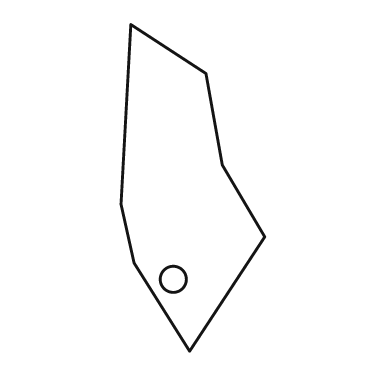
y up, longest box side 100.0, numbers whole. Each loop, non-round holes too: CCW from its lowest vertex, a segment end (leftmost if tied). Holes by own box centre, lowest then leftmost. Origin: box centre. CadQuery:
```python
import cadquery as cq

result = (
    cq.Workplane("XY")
    .moveTo(-1.0, -50.0)
    .lineTo(22.0, -15.0)
    .lineTo(9.0, 7.0)
    .lineTo(4.0, 35.0)
    .lineTo(-19.0, 50.0)
    .lineTo(-22.0, -5.0)
    .lineTo(-18.0, -23.0)
    .close()
    .moveTo(-6.0, -28.0)
    .circle(4.0)
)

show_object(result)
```